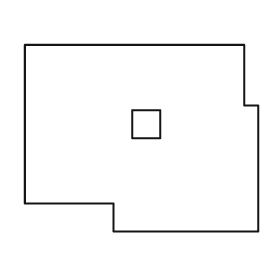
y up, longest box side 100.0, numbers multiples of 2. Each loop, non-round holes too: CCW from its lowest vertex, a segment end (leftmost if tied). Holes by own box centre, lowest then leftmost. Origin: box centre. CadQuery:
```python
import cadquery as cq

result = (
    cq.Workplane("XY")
    .moveTo(-12.0, -40.0)
    .lineTo(50.0, -40.0)
    .lineTo(50.0, 14.0)
    .lineTo(44.0, 14.0)
    .lineTo(44.0, 40.0)
    .lineTo(-50.0, 40.0)
    .lineTo(-50.0, -28.0)
    .lineTo(-12.0, -28.0)
    .close()
    .moveTo(-4.0, 0.0)
    .lineTo(8.0, 0.0)
    .lineTo(8.0, 12.0)
    .lineTo(-4.0, 12.0)
    .close()
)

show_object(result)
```